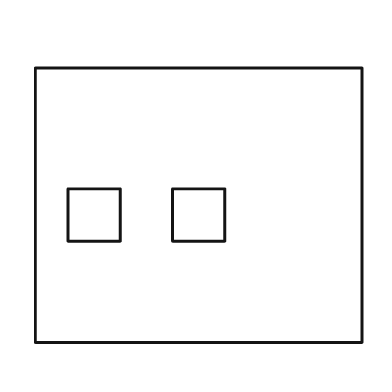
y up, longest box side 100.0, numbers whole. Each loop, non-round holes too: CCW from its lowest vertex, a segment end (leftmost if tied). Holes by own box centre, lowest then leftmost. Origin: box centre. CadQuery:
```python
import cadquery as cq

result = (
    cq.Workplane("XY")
    .moveTo(-50.0, -42.0)
    .lineTo(50.0, -42.0)
    .lineTo(50.0, 42.0)
    .lineTo(-50.0, 42.0)
    .close()
    .moveTo(-40.0, -11.0)
    .lineTo(-24.0, -11.0)
    .lineTo(-24.0, 5.0)
    .lineTo(-40.0, 5.0)
    .close()
    .moveTo(-8.0, -11.0)
    .lineTo(8.0, -11.0)
    .lineTo(8.0, 5.0)
    .lineTo(-8.0, 5.0)
    .close()
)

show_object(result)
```